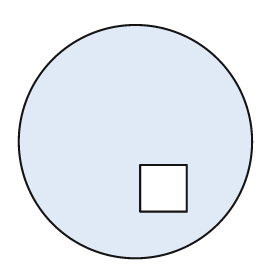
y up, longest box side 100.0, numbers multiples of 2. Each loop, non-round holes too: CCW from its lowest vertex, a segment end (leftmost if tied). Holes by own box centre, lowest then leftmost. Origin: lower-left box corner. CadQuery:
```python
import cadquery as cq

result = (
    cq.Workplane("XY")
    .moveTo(50.0, 50.0)
    .circle(50.0)
    .moveTo(52.0, 20.0)
    .lineTo(72.0, 20.0)
    .lineTo(72.0, 40.0)
    .lineTo(52.0, 40.0)
    .close()
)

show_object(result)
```